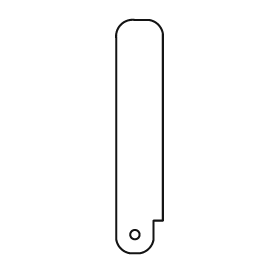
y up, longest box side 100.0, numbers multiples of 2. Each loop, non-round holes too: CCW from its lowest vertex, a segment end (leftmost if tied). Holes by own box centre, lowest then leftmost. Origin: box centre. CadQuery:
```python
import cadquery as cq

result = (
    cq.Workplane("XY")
    .moveTo(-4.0, -50.0)
    .lineTo(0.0, -50.0)
    .threePointArc((4.0, -48.0), (6.0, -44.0))
    .lineTo(6.0, -36.0)
    .lineTo(10.0, -36.0)
    .lineTo(10.0, 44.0)
    .threePointArc((8.0, 48.0), (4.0, 50.0))
    .lineTo(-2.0, 50.0)
    .threePointArc((-8.0, 48.0), (-10.0, 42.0))
    .lineTo(-10.0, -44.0)
    .threePointArc((-8.0, -48.0), (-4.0, -50.0))
    .close()
    .moveTo(-2.0, -42.0)
    .circle(2.0)
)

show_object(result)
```